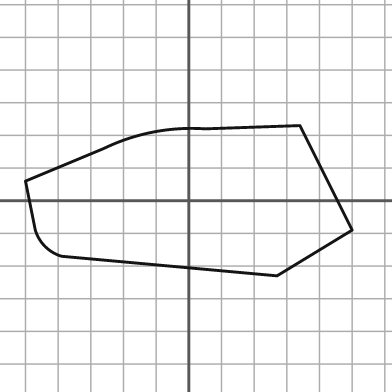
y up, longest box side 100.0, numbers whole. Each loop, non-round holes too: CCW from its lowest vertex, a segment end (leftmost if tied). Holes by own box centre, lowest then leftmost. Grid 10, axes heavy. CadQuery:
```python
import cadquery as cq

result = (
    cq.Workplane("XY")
    .moveTo(27.0, -23.0)
    .lineTo(50.0, -9.0)
    .lineTo(34.0, 23.0)
    .lineTo(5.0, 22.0)
    .threePointArc((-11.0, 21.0), (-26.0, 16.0))
    .lineTo(-50.0, 6.0)
    .lineTo(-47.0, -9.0)
    .threePointArc((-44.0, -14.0), (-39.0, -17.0))
    .close()
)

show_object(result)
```